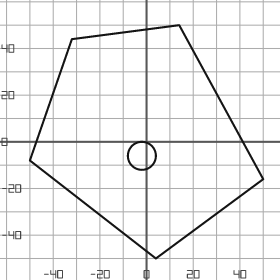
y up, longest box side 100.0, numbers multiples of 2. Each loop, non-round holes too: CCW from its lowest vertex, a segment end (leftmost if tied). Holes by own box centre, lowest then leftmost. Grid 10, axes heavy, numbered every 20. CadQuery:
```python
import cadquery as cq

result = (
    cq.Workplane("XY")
    .moveTo(4.0, -50.0)
    .lineTo(50.0, -16.0)
    .lineTo(14.0, 50.0)
    .lineTo(-32.0, 44.0)
    .lineTo(-50.0, -8.0)
    .close()
    .moveTo(-2.0, -6.0)
    .circle(6.0)
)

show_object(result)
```